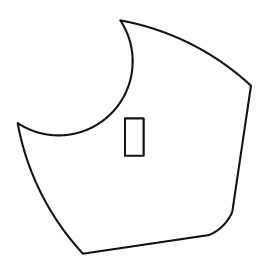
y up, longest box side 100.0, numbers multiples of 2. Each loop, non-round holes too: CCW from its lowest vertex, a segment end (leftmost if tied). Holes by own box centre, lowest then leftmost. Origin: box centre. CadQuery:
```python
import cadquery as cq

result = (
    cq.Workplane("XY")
    .moveTo(-22.0, -50.0)
    .lineTo(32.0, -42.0)
    .threePointArc((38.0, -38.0), (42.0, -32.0))
    .lineTo(50.0, 22.0)
    .threePointArc((24.0, 40.0), (-6.0, 50.0))
    .threePointArc((-10.0, 10.0), (-50.0, 6.0))
    .threePointArc((-40.0, -24.0), (-22.0, -50.0))
    .close()
    .moveTo(-4.0, -8.0)
    .lineTo(4.0, -8.0)
    .lineTo(4.0, 8.0)
    .lineTo(-4.0, 8.0)
    .close()
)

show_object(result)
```